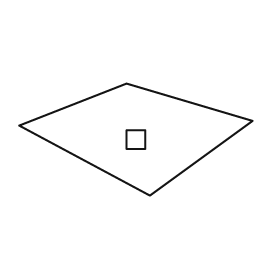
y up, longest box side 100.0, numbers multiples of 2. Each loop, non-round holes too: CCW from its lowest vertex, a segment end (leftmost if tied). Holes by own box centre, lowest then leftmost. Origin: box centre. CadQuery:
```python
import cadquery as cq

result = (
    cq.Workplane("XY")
    .moveTo(6.0, -24.0)
    .lineTo(50.0, 8.0)
    .lineTo(-4.0, 24.0)
    .lineTo(-50.0, 6.0)
    .close()
    .moveTo(-4.0, -4.0)
    .lineTo(4.0, -4.0)
    .lineTo(4.0, 4.0)
    .lineTo(-4.0, 4.0)
    .close()
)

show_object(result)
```